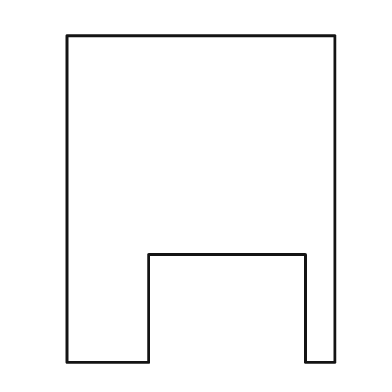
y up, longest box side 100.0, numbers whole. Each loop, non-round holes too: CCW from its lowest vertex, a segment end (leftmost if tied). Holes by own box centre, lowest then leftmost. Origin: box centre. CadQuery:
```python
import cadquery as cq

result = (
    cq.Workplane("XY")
    .moveTo(-41.0, -50.0)
    .lineTo(-16.0, -50.0)
    .lineTo(-16.0, -17.0)
    .lineTo(32.0, -17.0)
    .lineTo(32.0, -50.0)
    .lineTo(41.0, -50.0)
    .lineTo(41.0, 50.0)
    .lineTo(-41.0, 50.0)
    .close()
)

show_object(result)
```